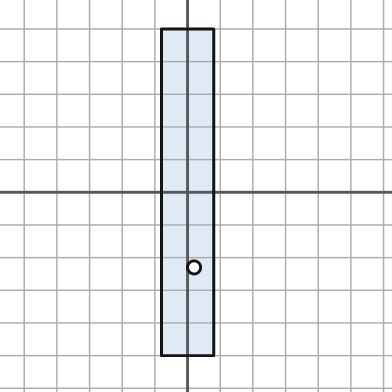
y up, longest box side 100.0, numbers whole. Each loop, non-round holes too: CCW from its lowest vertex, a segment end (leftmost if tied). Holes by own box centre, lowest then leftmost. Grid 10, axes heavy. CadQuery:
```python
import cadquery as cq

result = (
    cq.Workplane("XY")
    .moveTo(-8.0, -50.0)
    .lineTo(8.0, -50.0)
    .lineTo(8.0, 50.0)
    .lineTo(-8.0, 50.0)
    .close()
    .moveTo(2.0, -23.0)
    .circle(2.0)
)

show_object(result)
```